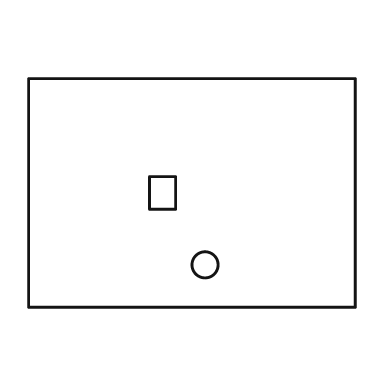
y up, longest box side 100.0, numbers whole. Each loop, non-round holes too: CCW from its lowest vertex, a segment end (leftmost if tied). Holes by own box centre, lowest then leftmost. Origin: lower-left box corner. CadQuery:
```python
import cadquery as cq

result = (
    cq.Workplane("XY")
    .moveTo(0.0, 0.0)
    .lineTo(100.0, 0.0)
    .lineTo(100.0, 70.0)
    .lineTo(0.0, 70.0)
    .close()
    .moveTo(54.0, 13.0)
    .circle(4.0)
    .moveTo(37.0, 30.0)
    .lineTo(45.0, 30.0)
    .lineTo(45.0, 40.0)
    .lineTo(37.0, 40.0)
    .close()
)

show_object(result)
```